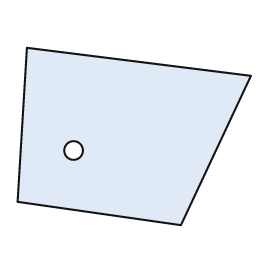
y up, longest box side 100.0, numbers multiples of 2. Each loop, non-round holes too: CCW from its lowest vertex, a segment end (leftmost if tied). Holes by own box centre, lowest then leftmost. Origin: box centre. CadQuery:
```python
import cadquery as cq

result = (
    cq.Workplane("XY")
    .moveTo(20.0, -38.0)
    .lineTo(50.0, 26.0)
    .lineTo(-46.0, 38.0)
    .lineTo(-50.0, -28.0)
    .close()
    .moveTo(-26.0, -6.0)
    .circle(4.0)
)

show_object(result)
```